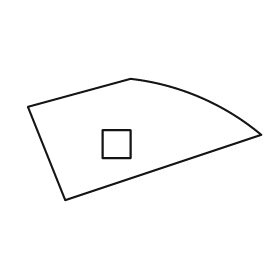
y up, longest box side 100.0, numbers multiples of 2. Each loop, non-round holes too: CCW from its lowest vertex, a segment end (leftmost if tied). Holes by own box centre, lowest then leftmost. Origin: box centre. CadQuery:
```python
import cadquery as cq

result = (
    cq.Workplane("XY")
    .moveTo(-34.0, -26.0)
    .lineTo(50.0, 2.0)
    .threePointArc((24.0, 18.0), (-6.0, 26.0))
    .lineTo(-50.0, 14.0)
    .close()
    .moveTo(-18.0, -8.0)
    .lineTo(-6.0, -8.0)
    .lineTo(-6.0, 4.0)
    .lineTo(-18.0, 4.0)
    .close()
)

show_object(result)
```